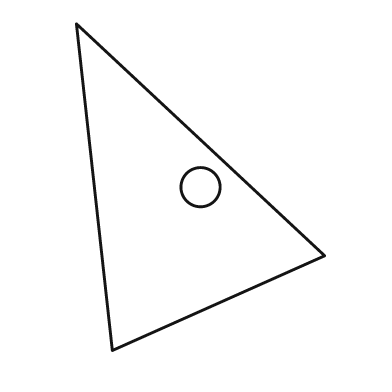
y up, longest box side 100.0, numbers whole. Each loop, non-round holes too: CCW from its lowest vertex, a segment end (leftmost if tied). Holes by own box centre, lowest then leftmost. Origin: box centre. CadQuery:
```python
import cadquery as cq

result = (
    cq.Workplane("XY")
    .moveTo(-27.0, -50.0)
    .lineTo(38.0, -21.0)
    .lineTo(-38.0, 50.0)
    .close()
    .moveTo(0.0, 0.0)
    .circle(6.0)
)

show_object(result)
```